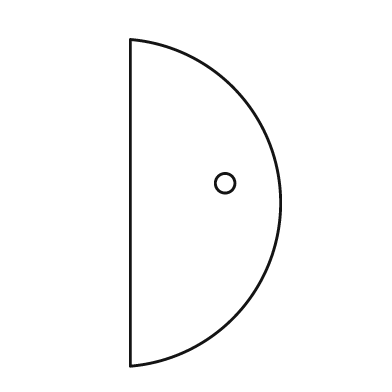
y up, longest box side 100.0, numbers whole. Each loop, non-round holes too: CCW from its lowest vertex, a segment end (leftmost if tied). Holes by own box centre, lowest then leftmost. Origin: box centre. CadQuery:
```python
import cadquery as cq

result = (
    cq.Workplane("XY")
    .moveTo(-23.0, -50.0)
    .threePointArc((23.0, 0.0), (-23.0, 50.0))
    .close()
    .moveTo(6.0, 6.0)
    .circle(3.0)
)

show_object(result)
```